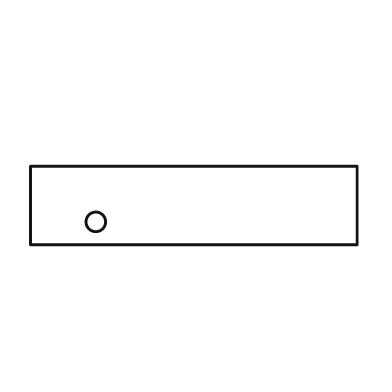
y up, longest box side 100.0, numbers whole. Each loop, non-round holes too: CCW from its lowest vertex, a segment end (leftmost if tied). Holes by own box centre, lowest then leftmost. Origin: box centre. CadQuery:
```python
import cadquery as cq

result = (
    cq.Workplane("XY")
    .moveTo(-50.0, -12.0)
    .lineTo(50.0, -12.0)
    .lineTo(50.0, 12.0)
    .lineTo(-50.0, 12.0)
    .close()
    .moveTo(-30.0, -5.0)
    .circle(3.0)
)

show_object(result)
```